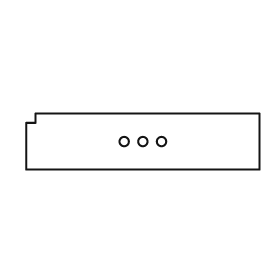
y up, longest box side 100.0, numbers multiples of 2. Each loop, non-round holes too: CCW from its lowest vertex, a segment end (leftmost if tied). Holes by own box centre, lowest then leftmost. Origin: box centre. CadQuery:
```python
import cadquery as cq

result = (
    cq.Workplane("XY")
    .moveTo(-50.0, -12.0)
    .lineTo(50.0, -12.0)
    .lineTo(50.0, 12.0)
    .lineTo(-46.0, 12.0)
    .lineTo(-46.0, 8.0)
    .lineTo(-50.0, 8.0)
    .close()
    .moveTo(-8.0, 0.0)
    .circle(2.0)
    .moveTo(0.0, 0.0)
    .circle(2.0)
    .moveTo(8.0, 0.0)
    .circle(2.0)
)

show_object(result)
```